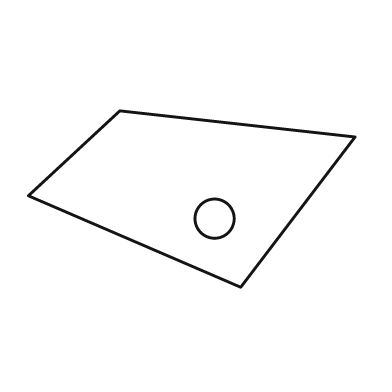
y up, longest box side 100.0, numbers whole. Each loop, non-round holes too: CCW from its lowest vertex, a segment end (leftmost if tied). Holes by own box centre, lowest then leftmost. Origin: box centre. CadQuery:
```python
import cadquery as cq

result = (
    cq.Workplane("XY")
    .moveTo(15.0, -27.0)
    .lineTo(50.0, 19.0)
    .lineTo(-22.0, 27.0)
    .lineTo(-50.0, 1.0)
    .close()
    .moveTo(7.0, -6.0)
    .circle(6.0)
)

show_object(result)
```